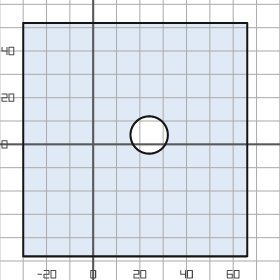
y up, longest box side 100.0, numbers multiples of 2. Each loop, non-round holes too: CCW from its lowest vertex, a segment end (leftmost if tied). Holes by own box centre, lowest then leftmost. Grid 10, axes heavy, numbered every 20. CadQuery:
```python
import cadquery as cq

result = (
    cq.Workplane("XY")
    .moveTo(-30.0, -48.0)
    .lineTo(66.0, -48.0)
    .lineTo(66.0, 52.0)
    .lineTo(-30.0, 52.0)
    .close()
    .moveTo(24.0, 4.0)
    .circle(8.0)
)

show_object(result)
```